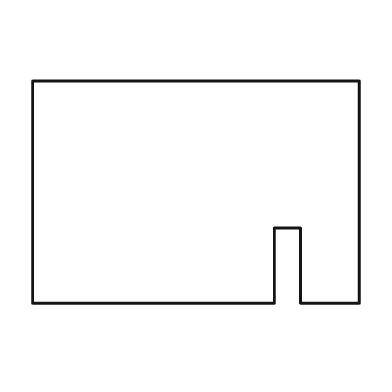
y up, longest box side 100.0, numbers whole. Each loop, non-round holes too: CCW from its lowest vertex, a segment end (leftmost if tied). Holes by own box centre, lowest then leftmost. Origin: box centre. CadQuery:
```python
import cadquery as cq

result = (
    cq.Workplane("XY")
    .moveTo(-50.0, -34.0)
    .lineTo(24.0, -34.0)
    .lineTo(24.0, -11.0)
    .lineTo(32.0, -11.0)
    .lineTo(32.0, -34.0)
    .lineTo(50.0, -34.0)
    .lineTo(50.0, 34.0)
    .lineTo(-50.0, 34.0)
    .close()
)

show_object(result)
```